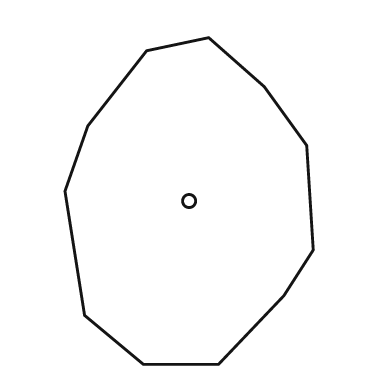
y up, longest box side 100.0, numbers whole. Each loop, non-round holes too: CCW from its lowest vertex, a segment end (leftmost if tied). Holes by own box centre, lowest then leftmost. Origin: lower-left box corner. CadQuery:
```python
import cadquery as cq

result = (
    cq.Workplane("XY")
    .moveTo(24.0, 0.0)
    .lineTo(47.0, 0.0)
    .lineTo(67.0, 21.0)
    .lineTo(76.0, 35.0)
    .lineTo(74.0, 67.0)
    .lineTo(61.0, 85.0)
    .lineTo(44.0, 100.0)
    .lineTo(25.0, 96.0)
    .lineTo(7.0, 73.0)
    .lineTo(0.0, 53.0)
    .lineTo(6.0, 15.0)
    .close()
    .moveTo(38.0, 50.0)
    .circle(2.0)
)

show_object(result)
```